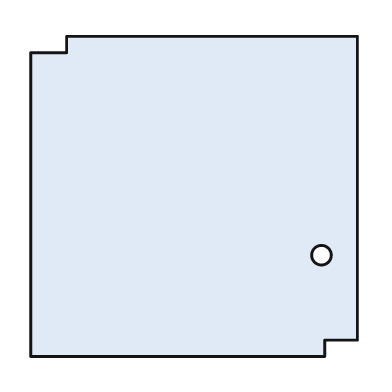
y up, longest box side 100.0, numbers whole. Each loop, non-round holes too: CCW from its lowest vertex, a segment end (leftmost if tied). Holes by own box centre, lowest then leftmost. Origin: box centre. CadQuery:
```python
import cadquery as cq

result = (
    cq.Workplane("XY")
    .moveTo(-50.0, -49.0)
    .lineTo(40.0, -49.0)
    .lineTo(40.0, -44.0)
    .lineTo(50.0, -44.0)
    .lineTo(50.0, 49.0)
    .lineTo(-39.0, 49.0)
    .lineTo(-39.0, 44.0)
    .lineTo(-50.0, 44.0)
    .close()
    .moveTo(39.0, -18.0)
    .circle(3.0)
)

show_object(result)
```